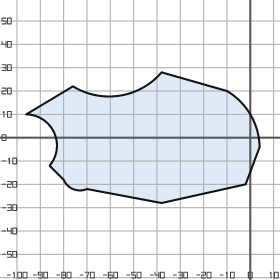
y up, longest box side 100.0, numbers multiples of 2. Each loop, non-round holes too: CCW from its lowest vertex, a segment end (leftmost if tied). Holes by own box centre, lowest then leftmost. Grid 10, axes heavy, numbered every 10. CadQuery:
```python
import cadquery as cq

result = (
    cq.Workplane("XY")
    .moveTo(-38.0, -28.0)
    .lineTo(-2.0, -20.0)
    .lineTo(4.0, -4.0)
    .threePointArc((0.0, 10.0), (-10.0, 20.0))
    .lineTo(-38.0, 28.0)
    .threePointArc((-56.0, 18.0), (-76.0, 22.0))
    .lineTo(-96.0, 10.0)
    .threePointArc((-84.0, 2.0), (-86.0, -12.0))
    .lineTo(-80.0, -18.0)
    .threePointArc((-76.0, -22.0), (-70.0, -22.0))
    .close()
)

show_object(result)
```